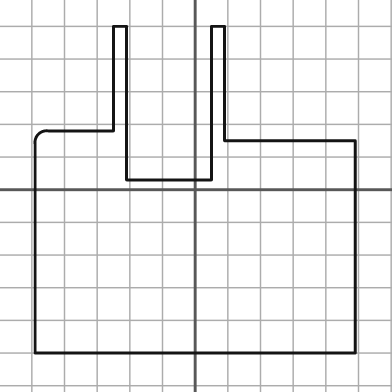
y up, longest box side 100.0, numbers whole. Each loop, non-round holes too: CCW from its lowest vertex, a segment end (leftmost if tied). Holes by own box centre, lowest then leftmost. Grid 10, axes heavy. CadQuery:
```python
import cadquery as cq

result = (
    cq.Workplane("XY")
    .moveTo(-49.0, -50.0)
    .lineTo(49.0, -50.0)
    .lineTo(49.0, 15.0)
    .lineTo(9.0, 15.0)
    .lineTo(9.0, 50.0)
    .lineTo(5.0, 50.0)
    .lineTo(5.0, 3.0)
    .lineTo(-21.0, 3.0)
    .lineTo(-21.0, 50.0)
    .lineTo(-25.0, 50.0)
    .lineTo(-25.0, 18.0)
    .lineTo(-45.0, 18.0)
    .threePointArc((-48.0, 17.0), (-49.0, 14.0))
    .close()
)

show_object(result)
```